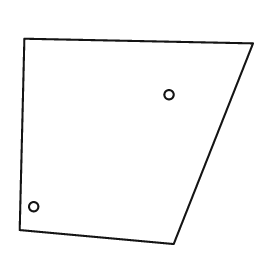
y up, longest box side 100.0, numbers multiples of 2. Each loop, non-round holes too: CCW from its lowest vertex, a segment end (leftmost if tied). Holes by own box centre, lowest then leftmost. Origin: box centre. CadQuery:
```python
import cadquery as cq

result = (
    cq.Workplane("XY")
    .moveTo(16.0, -44.0)
    .lineTo(50.0, 42.0)
    .lineTo(-48.0, 44.0)
    .lineTo(-50.0, -38.0)
    .close()
    .moveTo(-44.0, -28.0)
    .circle(2.0)
    .moveTo(14.0, 20.0)
    .circle(2.0)
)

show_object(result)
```